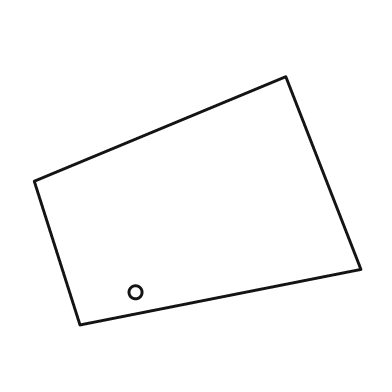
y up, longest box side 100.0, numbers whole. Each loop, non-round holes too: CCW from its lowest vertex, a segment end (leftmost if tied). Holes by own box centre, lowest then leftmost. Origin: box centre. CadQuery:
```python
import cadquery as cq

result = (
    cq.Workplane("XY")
    .moveTo(-36.0, -38.0)
    .lineTo(50.0, -21.0)
    .lineTo(27.0, 38.0)
    .lineTo(-50.0, 6.0)
    .close()
    .moveTo(-19.0, -28.0)
    .circle(2.0)
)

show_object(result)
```